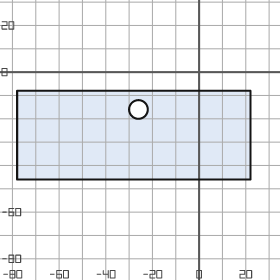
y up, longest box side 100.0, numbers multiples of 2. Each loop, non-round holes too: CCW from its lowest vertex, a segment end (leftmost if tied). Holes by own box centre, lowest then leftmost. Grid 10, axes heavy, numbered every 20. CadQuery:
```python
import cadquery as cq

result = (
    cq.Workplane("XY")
    .moveTo(-78.0, -46.0)
    .lineTo(22.0, -46.0)
    .lineTo(22.0, -8.0)
    .lineTo(-78.0, -8.0)
    .close()
    .moveTo(-26.0, -16.0)
    .circle(4.0)
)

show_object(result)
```